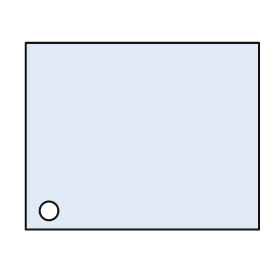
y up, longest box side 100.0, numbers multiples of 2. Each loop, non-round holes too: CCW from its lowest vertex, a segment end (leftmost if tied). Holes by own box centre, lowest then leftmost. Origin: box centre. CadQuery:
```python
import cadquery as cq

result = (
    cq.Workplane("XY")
    .moveTo(-50.0, -40.0)
    .lineTo(50.0, -40.0)
    .lineTo(50.0, 40.0)
    .lineTo(-50.0, 40.0)
    .close()
    .moveTo(-40.0, -32.0)
    .circle(4.0)
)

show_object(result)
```